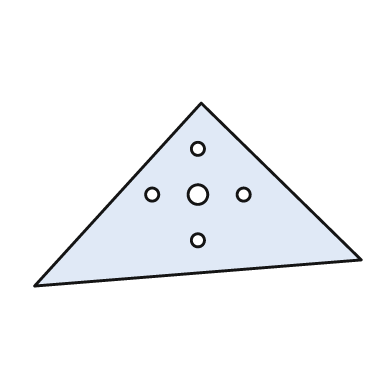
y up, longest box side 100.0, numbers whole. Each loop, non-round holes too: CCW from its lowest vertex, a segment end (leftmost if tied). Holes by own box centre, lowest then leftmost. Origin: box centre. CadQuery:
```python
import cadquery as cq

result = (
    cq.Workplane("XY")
    .moveTo(-50.0, -28.0)
    .lineTo(50.0, -20.0)
    .lineTo(1.0, 28.0)
    .close()
    .moveTo(0.0, -14.0)
    .circle(2.0)
    .moveTo(-14.0, 0.0)
    .circle(2.0)
    .moveTo(0.0, 0.0)
    .circle(3.0)
    .moveTo(14.0, 0.0)
    .circle(2.0)
    .moveTo(0.0, 14.0)
    .circle(2.0)
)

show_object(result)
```